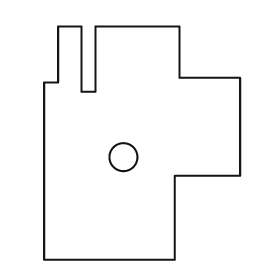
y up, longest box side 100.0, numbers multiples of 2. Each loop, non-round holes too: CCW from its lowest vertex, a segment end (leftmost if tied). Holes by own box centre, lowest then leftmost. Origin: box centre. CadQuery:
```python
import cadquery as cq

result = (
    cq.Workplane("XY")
    .moveTo(-42.0, -50.0)
    .lineTo(14.0, -50.0)
    .lineTo(14.0, -14.0)
    .lineTo(42.0, -14.0)
    .lineTo(42.0, 28.0)
    .lineTo(16.0, 28.0)
    .lineTo(16.0, 50.0)
    .lineTo(-20.0, 50.0)
    .lineTo(-20.0, 22.0)
    .lineTo(-26.0, 22.0)
    .lineTo(-26.0, 50.0)
    .lineTo(-36.0, 50.0)
    .lineTo(-36.0, 26.0)
    .lineTo(-42.0, 26.0)
    .close()
    .moveTo(-8.0, -6.0)
    .circle(6.0)
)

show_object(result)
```